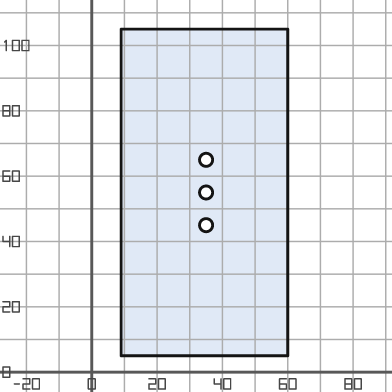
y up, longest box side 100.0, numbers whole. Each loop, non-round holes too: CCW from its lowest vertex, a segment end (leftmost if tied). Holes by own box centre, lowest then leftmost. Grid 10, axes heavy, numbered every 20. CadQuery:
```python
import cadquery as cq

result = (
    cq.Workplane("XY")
    .moveTo(9.0, 5.0)
    .lineTo(60.0, 5.0)
    .lineTo(60.0, 105.0)
    .lineTo(9.0, 105.0)
    .close()
    .moveTo(35.0, 45.0)
    .circle(2.0)
    .moveTo(35.0, 55.0)
    .circle(2.0)
    .moveTo(35.0, 65.0)
    .circle(2.0)
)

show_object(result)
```